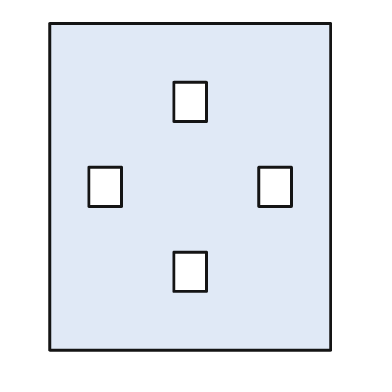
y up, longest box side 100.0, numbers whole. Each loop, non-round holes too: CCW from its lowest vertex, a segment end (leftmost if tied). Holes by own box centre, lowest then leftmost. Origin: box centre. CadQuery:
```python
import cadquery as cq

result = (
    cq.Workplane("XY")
    .moveTo(-43.0, -50.0)
    .lineTo(43.0, -50.0)
    .lineTo(43.0, 50.0)
    .lineTo(-43.0, 50.0)
    .close()
    .moveTo(-5.0, -32.0)
    .lineTo(5.0, -32.0)
    .lineTo(5.0, -20.0)
    .lineTo(-5.0, -20.0)
    .close()
    .moveTo(-31.0, -6.0)
    .lineTo(-21.0, -6.0)
    .lineTo(-21.0, 6.0)
    .lineTo(-31.0, 6.0)
    .close()
    .moveTo(21.0, -6.0)
    .lineTo(31.0, -6.0)
    .lineTo(31.0, 6.0)
    .lineTo(21.0, 6.0)
    .close()
    .moveTo(-5.0, 20.0)
    .lineTo(5.0, 20.0)
    .lineTo(5.0, 32.0)
    .lineTo(-5.0, 32.0)
    .close()
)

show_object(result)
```